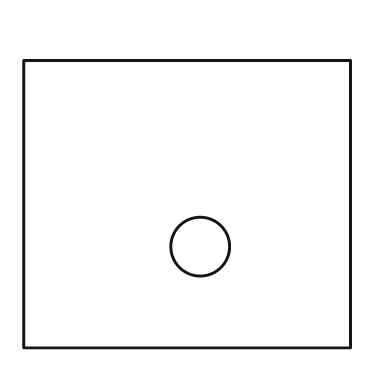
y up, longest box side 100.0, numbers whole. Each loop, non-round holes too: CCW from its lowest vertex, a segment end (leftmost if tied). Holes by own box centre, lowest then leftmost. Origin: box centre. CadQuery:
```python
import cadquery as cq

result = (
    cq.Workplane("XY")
    .moveTo(-50.0, -44.0)
    .lineTo(50.0, -44.0)
    .lineTo(50.0, 44.0)
    .lineTo(-50.0, 44.0)
    .close()
    .moveTo(4.0, -13.0)
    .circle(9.0)
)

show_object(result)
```